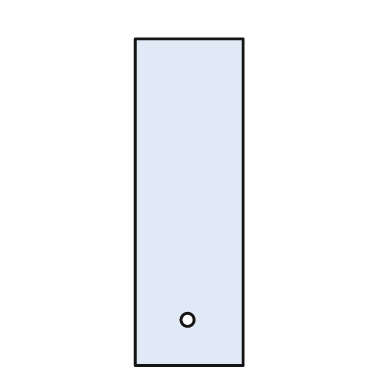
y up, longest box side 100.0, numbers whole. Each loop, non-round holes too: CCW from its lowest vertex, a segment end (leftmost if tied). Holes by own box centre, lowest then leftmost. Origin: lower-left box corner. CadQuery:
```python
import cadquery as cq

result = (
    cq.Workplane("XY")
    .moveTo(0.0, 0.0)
    .lineTo(33.0, 0.0)
    .lineTo(33.0, 100.0)
    .lineTo(0.0, 100.0)
    .close()
    .moveTo(16.0, 14.0)
    .circle(2.0)
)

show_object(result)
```